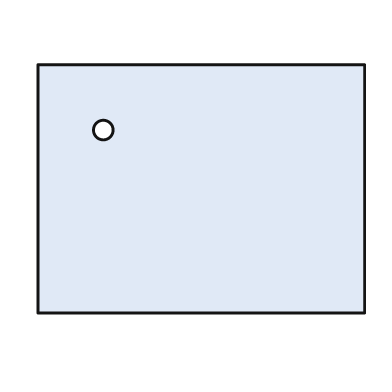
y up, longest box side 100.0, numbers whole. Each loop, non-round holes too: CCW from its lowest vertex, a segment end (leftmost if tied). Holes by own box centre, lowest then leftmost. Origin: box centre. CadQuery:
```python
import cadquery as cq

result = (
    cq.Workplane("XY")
    .moveTo(-50.0, -38.0)
    .lineTo(50.0, -38.0)
    .lineTo(50.0, 38.0)
    .lineTo(-50.0, 38.0)
    .close()
    .moveTo(-30.0, 18.0)
    .circle(3.0)
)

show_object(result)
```